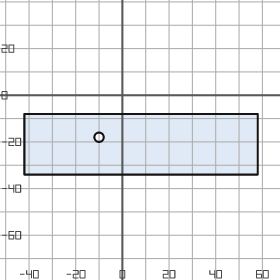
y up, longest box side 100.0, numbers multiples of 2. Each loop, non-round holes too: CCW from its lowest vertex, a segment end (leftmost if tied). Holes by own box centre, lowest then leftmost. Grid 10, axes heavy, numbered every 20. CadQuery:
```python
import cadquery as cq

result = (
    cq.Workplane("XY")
    .moveTo(-42.0, -34.0)
    .lineTo(58.0, -34.0)
    .lineTo(58.0, -8.0)
    .lineTo(-42.0, -8.0)
    .close()
    .moveTo(-10.0, -18.0)
    .circle(2.0)
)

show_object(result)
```